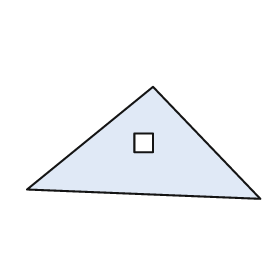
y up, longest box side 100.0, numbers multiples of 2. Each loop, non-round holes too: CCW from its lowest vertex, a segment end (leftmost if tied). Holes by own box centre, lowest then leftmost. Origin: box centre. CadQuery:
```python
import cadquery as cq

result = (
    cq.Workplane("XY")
    .moveTo(50.0, -24.0)
    .lineTo(4.0, 24.0)
    .lineTo(-50.0, -20.0)
    .close()
    .moveTo(-4.0, -4.0)
    .lineTo(4.0, -4.0)
    .lineTo(4.0, 4.0)
    .lineTo(-4.0, 4.0)
    .close()
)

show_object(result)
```